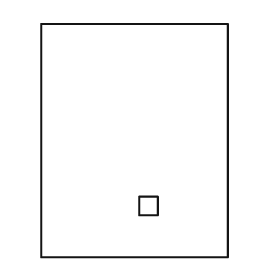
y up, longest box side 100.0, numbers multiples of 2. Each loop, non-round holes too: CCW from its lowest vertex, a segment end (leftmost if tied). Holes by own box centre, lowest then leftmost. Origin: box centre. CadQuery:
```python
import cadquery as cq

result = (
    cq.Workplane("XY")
    .moveTo(-40.0, -50.0)
    .lineTo(40.0, -50.0)
    .lineTo(40.0, 50.0)
    .lineTo(-40.0, 50.0)
    .close()
    .moveTo(2.0, -32.0)
    .lineTo(10.0, -32.0)
    .lineTo(10.0, -24.0)
    .lineTo(2.0, -24.0)
    .close()
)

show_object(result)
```